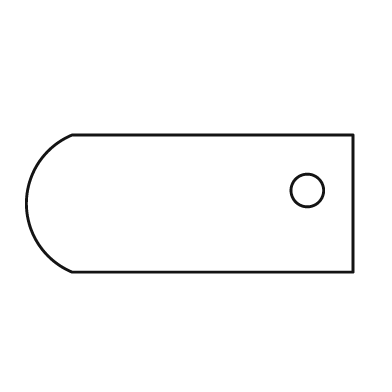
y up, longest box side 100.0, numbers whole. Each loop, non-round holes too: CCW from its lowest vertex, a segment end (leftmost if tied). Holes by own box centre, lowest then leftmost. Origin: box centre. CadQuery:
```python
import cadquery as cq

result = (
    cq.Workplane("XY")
    .moveTo(-36.0, -21.0)
    .lineTo(50.0, -21.0)
    .lineTo(50.0, 21.0)
    .lineTo(-36.0, 21.0)
    .threePointArc((-50.0, 0.0), (-36.0, -21.0))
    .close()
    .moveTo(36.0, 4.0)
    .circle(5.0)
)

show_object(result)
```